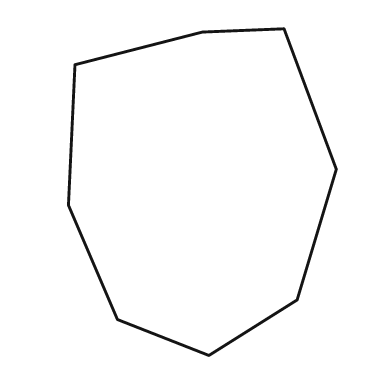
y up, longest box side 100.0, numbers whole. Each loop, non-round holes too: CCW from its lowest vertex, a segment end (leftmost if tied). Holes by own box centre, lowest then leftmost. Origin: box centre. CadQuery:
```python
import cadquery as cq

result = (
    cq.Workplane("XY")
    .moveTo(2.0, -50.0)
    .lineTo(29.0, -33.0)
    .lineTo(41.0, 7.0)
    .lineTo(25.0, 50.0)
    .lineTo(0.0, 49.0)
    .lineTo(-39.0, 39.0)
    .lineTo(-41.0, -4.0)
    .lineTo(-26.0, -39.0)
    .close()
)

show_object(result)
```